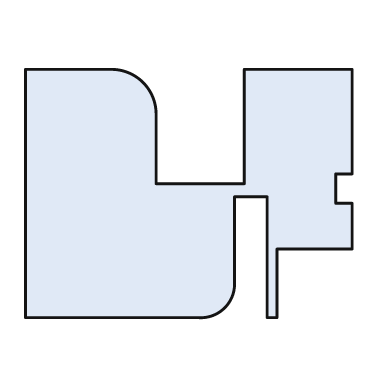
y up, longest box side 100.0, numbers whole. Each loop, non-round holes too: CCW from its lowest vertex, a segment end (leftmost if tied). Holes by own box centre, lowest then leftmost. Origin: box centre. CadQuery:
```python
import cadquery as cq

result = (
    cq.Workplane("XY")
    .moveTo(-50.0, -38.0)
    .lineTo(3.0, -38.0)
    .threePointArc((11.0, -35.0), (14.0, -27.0))
    .lineTo(14.0, -1.0)
    .lineTo(24.0, -1.0)
    .lineTo(24.0, -38.0)
    .lineTo(27.0, -38.0)
    .lineTo(27.0, -17.0)
    .lineTo(50.0, -17.0)
    .lineTo(50.0, -3.0)
    .lineTo(45.0, -3.0)
    .lineTo(45.0, 6.0)
    .lineTo(50.0, 6.0)
    .lineTo(50.0, 38.0)
    .lineTo(17.0, 38.0)
    .lineTo(17.0, 3.0)
    .lineTo(-10.0, 3.0)
    .lineTo(-10.0, 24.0)
    .threePointArc((-14.0, 34.0), (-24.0, 38.0))
    .lineTo(-50.0, 38.0)
    .close()
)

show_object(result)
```